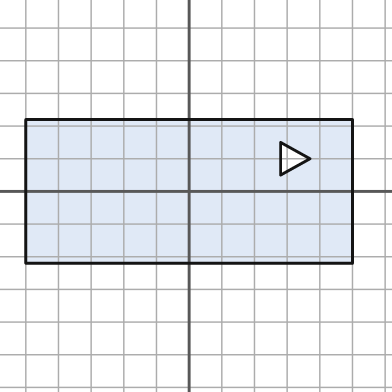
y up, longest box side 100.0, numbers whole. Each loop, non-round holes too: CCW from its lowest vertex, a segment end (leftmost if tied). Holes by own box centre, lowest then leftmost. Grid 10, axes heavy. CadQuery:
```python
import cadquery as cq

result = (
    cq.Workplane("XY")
    .moveTo(-50.0, -22.0)
    .lineTo(50.0, -22.0)
    .lineTo(50.0, 22.0)
    .lineTo(-50.0, 22.0)
    .close()
    .moveTo(28.0, 5.0)
    .lineTo(37.0, 10.0)
    .lineTo(28.0, 15.0)
    .close()
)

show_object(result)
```